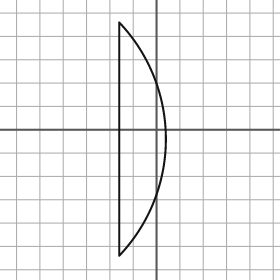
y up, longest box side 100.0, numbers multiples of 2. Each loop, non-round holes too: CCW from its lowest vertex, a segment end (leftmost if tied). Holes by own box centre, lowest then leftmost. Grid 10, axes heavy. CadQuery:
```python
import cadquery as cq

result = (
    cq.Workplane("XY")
    .moveTo(-16.0, -54.0)
    .threePointArc((4.0, -4.0), (-16.0, 46.0))
    .close()
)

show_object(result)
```